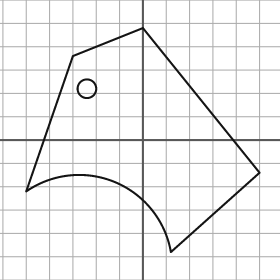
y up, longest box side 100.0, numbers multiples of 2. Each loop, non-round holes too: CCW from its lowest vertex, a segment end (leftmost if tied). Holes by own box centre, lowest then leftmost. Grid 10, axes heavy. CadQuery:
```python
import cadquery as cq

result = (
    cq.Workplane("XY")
    .moveTo(12.0, -48.0)
    .lineTo(50.0, -14.0)
    .lineTo(0.0, 48.0)
    .lineTo(-30.0, 36.0)
    .lineTo(-50.0, -22.0)
    .threePointArc((-12.0, -18.0), (12.0, -48.0))
    .close()
    .moveTo(-24.0, 22.0)
    .circle(4.0)
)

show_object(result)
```